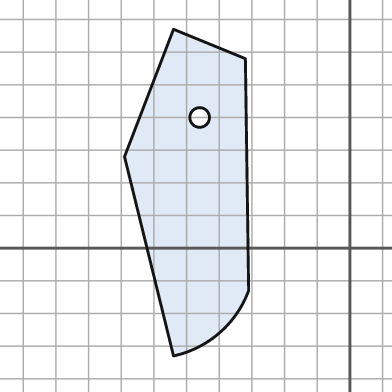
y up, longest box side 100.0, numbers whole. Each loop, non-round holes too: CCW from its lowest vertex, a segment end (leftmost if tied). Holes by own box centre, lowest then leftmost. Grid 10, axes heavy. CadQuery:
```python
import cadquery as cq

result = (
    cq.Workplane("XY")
    .moveTo(-54.0, -33.0)
    .threePointArc((-40.0, -26.0), (-31.0, -13.0))
    .lineTo(-32.0, 58.0)
    .lineTo(-54.0, 67.0)
    .lineTo(-69.0, 28.0)
    .close()
    .moveTo(-46.0, 40.0)
    .circle(3.0)
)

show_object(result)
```